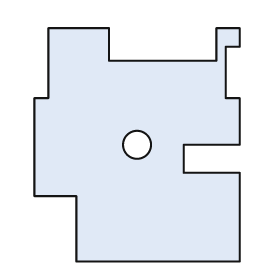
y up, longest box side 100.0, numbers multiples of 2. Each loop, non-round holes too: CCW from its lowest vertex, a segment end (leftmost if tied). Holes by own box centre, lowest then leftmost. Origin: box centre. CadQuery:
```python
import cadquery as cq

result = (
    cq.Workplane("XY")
    .moveTo(-26.0, -50.0)
    .lineTo(44.0, -50.0)
    .lineTo(44.0, -12.0)
    .lineTo(20.0, -12.0)
    .lineTo(20.0, 0.0)
    .lineTo(44.0, 0.0)
    .lineTo(44.0, 20.0)
    .lineTo(38.0, 20.0)
    .lineTo(38.0, 42.0)
    .lineTo(44.0, 42.0)
    .lineTo(44.0, 50.0)
    .lineTo(34.0, 50.0)
    .lineTo(34.0, 36.0)
    .lineTo(-12.0, 36.0)
    .lineTo(-12.0, 50.0)
    .lineTo(-38.0, 50.0)
    .lineTo(-38.0, 20.0)
    .lineTo(-44.0, 20.0)
    .lineTo(-44.0, -22.0)
    .lineTo(-26.0, -22.0)
    .close()
    .moveTo(0.0, 0.0)
    .circle(6.0)
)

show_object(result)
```